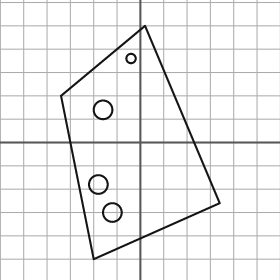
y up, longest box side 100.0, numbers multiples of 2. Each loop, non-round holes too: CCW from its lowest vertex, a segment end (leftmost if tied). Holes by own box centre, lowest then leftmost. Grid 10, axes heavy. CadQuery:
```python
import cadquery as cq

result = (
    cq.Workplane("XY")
    .moveTo(-20.0, -50.0)
    .lineTo(34.0, -26.0)
    .lineTo(2.0, 50.0)
    .lineTo(-34.0, 20.0)
    .close()
    .moveTo(-12.0, -30.0)
    .circle(4.0)
    .moveTo(-18.0, -18.0)
    .circle(4.0)
    .moveTo(-16.0, 14.0)
    .circle(4.0)
    .moveTo(-4.0, 36.0)
    .circle(2.0)
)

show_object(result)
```